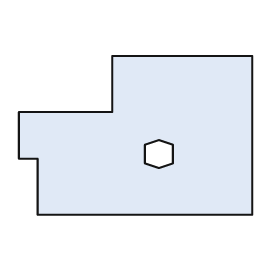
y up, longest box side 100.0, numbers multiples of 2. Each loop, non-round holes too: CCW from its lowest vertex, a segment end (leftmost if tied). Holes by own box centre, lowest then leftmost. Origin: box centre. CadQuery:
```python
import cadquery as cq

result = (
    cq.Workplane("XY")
    .moveTo(-42.0, -34.0)
    .lineTo(50.0, -34.0)
    .lineTo(50.0, 34.0)
    .lineTo(-10.0, 34.0)
    .lineTo(-10.0, 10.0)
    .lineTo(-50.0, 10.0)
    .lineTo(-50.0, -10.0)
    .lineTo(-42.0, -10.0)
    .close()
    .moveTo(10.0, -14.0)
    .lineTo(16.0, -12.0)
    .lineTo(16.0, -4.0)
    .lineTo(10.0, -2.0)
    .lineTo(4.0, -4.0)
    .lineTo(4.0, -12.0)
    .close()
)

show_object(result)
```